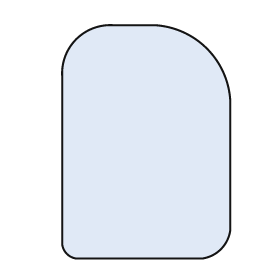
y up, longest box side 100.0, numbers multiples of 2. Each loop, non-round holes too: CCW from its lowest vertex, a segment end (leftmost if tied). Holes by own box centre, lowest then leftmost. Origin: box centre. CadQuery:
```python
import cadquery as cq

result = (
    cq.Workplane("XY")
    .moveTo(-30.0, -50.0)
    .lineTo(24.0, -50.0)
    .threePointArc((32.0, -46.0), (36.0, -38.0))
    .lineTo(36.0, 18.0)
    .threePointArc((26.0, 40.0), (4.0, 50.0))
    .lineTo(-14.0, 50.0)
    .threePointArc((-30.0, 44.0), (-36.0, 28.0))
    .lineTo(-36.0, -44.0)
    .threePointArc((-34.0, -48.0), (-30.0, -50.0))
    .close()
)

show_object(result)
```